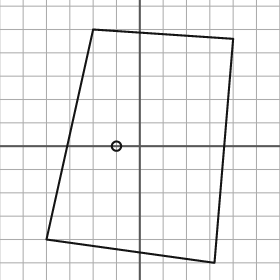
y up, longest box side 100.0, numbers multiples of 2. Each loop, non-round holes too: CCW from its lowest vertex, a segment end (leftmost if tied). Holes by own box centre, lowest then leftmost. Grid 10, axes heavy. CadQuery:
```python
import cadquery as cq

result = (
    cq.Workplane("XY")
    .moveTo(32.0, -50.0)
    .lineTo(40.0, 46.0)
    .lineTo(-20.0, 50.0)
    .lineTo(-40.0, -40.0)
    .close()
    .moveTo(-10.0, 0.0)
    .circle(2.0)
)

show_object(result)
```